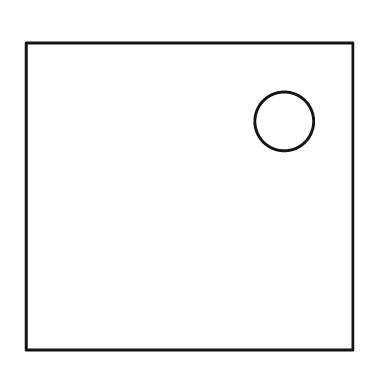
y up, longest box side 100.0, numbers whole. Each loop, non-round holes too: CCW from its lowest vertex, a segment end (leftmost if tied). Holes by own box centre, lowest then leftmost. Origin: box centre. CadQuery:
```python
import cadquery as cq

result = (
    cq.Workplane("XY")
    .moveTo(-50.0, -47.0)
    .lineTo(50.0, -47.0)
    .lineTo(50.0, 47.0)
    .lineTo(-50.0, 47.0)
    .close()
    .moveTo(29.0, 23.0)
    .circle(9.0)
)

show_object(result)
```